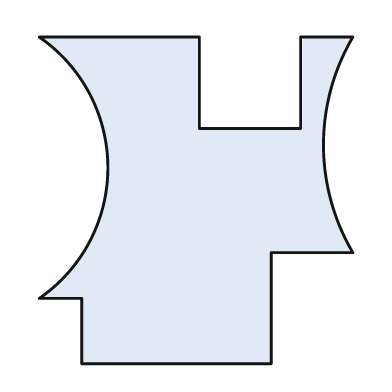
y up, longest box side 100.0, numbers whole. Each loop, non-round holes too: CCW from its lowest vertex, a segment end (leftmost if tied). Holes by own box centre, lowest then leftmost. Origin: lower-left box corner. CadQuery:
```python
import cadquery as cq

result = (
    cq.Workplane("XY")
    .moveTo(13.0, 0.0)
    .lineTo(71.0, 0.0)
    .lineTo(71.0, 34.0)
    .lineTo(96.0, 34.0)
    .threePointArc((87.0, 67.0), (96.0, 100.0))
    .lineTo(80.0, 100.0)
    .lineTo(80.0, 72.0)
    .lineTo(49.0, 72.0)
    .lineTo(49.0, 100.0)
    .lineTo(0.0, 100.0)
    .threePointArc((21.0, 60.0), (0.0, 20.0))
    .lineTo(13.0, 20.0)
    .close()
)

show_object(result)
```